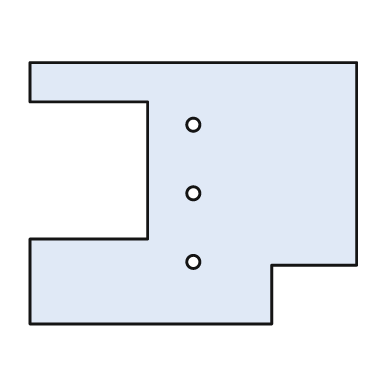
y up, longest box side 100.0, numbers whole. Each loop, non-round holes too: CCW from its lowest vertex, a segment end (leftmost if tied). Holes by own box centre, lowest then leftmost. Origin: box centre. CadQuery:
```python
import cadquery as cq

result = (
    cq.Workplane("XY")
    .moveTo(-50.0, -40.0)
    .lineTo(24.0, -40.0)
    .lineTo(24.0, -22.0)
    .lineTo(50.0, -22.0)
    .lineTo(50.0, 40.0)
    .lineTo(-50.0, 40.0)
    .lineTo(-50.0, 28.0)
    .lineTo(-14.0, 28.0)
    .lineTo(-14.0, -14.0)
    .lineTo(-50.0, -14.0)
    .close()
    .moveTo(0.0, -21.0)
    .circle(2.0)
    .moveTo(0.0, 0.0)
    .circle(2.0)
    .moveTo(0.0, 21.0)
    .circle(2.0)
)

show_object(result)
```